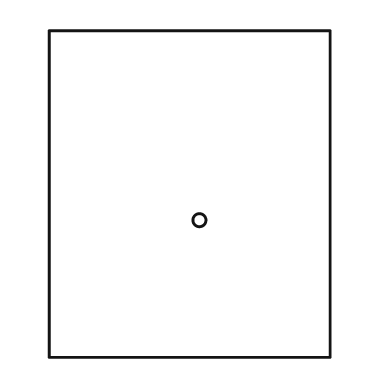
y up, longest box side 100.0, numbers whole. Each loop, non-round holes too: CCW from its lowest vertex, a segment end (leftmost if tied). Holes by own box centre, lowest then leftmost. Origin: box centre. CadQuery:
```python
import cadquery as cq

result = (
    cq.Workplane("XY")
    .moveTo(-43.0, -50.0)
    .lineTo(43.0, -50.0)
    .lineTo(43.0, 50.0)
    .lineTo(-43.0, 50.0)
    .close()
    .moveTo(3.0, -8.0)
    .circle(2.0)
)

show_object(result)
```